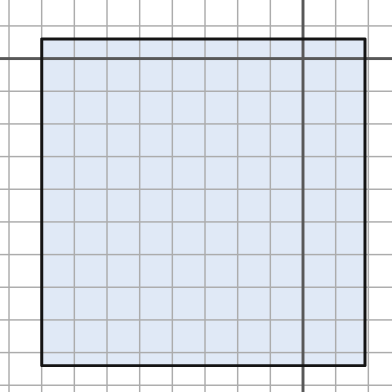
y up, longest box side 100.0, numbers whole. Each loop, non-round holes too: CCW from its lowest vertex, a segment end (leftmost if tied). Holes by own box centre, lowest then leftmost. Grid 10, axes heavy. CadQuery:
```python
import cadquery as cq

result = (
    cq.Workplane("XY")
    .moveTo(-80.0, -94.0)
    .lineTo(19.0, -94.0)
    .lineTo(19.0, 6.0)
    .lineTo(-80.0, 6.0)
    .close()
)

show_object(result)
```